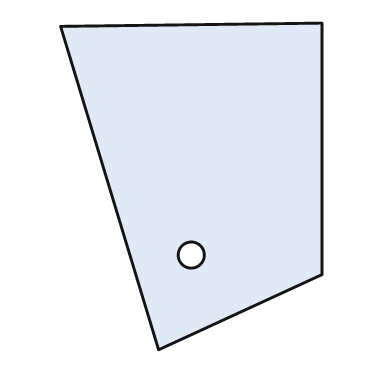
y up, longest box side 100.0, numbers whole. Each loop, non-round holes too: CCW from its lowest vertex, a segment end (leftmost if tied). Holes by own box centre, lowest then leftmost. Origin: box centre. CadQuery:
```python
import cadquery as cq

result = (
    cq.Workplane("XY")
    .moveTo(-10.0, -50.0)
    .lineTo(40.0, -27.0)
    .lineTo(40.0, 50.0)
    .lineTo(-40.0, 49.0)
    .close()
    .moveTo(0.0, -21.0)
    .circle(4.0)
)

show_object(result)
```